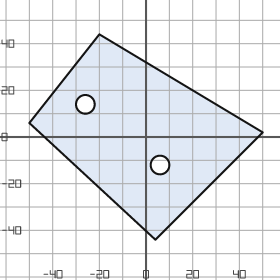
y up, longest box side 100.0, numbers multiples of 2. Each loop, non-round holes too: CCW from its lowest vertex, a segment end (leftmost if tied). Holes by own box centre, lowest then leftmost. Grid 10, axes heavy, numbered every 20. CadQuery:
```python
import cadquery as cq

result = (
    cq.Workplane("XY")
    .moveTo(4.0, -44.0)
    .lineTo(50.0, 2.0)
    .lineTo(-20.0, 44.0)
    .lineTo(-50.0, 6.0)
    .close()
    .moveTo(6.0, -12.0)
    .circle(4.0)
    .moveTo(-26.0, 14.0)
    .circle(4.0)
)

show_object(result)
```